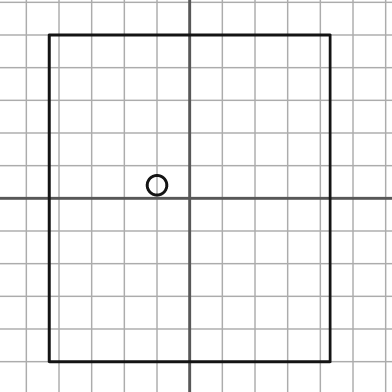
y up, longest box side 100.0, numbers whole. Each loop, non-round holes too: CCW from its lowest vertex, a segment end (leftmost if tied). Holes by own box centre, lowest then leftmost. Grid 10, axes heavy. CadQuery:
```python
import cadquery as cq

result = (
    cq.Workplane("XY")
    .moveTo(-43.0, -50.0)
    .lineTo(43.0, -50.0)
    .lineTo(43.0, 50.0)
    .lineTo(-43.0, 50.0)
    .close()
    .moveTo(-10.0, 4.0)
    .circle(3.0)
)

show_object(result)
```